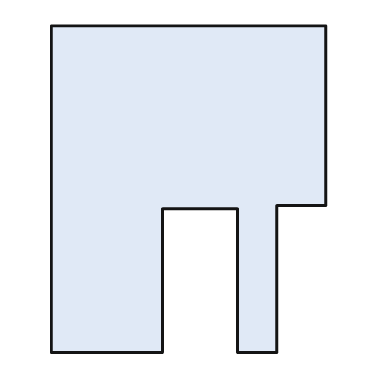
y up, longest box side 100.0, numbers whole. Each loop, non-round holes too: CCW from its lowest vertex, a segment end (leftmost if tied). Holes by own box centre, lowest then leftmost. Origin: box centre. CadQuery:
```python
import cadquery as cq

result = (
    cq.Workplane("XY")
    .moveTo(-42.0, -50.0)
    .lineTo(-8.0, -50.0)
    .lineTo(-8.0, -6.0)
    .lineTo(15.0, -6.0)
    .lineTo(15.0, -50.0)
    .lineTo(27.0, -50.0)
    .lineTo(27.0, -5.0)
    .lineTo(42.0, -5.0)
    .lineTo(42.0, 50.0)
    .lineTo(-42.0, 50.0)
    .close()
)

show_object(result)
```